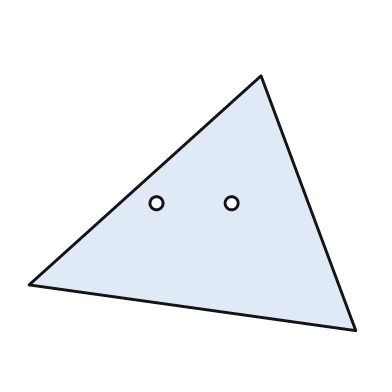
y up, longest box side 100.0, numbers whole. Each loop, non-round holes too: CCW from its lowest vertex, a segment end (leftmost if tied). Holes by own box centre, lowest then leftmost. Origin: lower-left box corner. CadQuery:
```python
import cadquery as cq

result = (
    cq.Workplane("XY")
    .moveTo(100.0, 0.0)
    .lineTo(71.0, 78.0)
    .lineTo(0.0, 14.0)
    .close()
    .moveTo(39.0, 39.0)
    .circle(2.0)
    .moveTo(62.0, 39.0)
    .circle(2.0)
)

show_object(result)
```